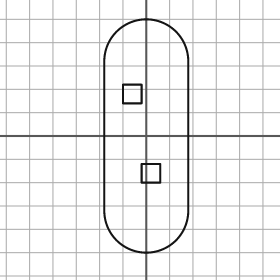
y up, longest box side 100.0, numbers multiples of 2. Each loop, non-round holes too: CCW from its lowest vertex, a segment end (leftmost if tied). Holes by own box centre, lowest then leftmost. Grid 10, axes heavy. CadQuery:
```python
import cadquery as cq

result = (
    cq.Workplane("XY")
    .moveTo(-18.0, -32.0)
    .threePointArc((0.0, -50.0), (18.0, -32.0))
    .lineTo(18.0, 32.0)
    .threePointArc((0.0, 50.0), (-18.0, 32.0))
    .close()
    .moveTo(-2.0, -20.0)
    .lineTo(6.0, -20.0)
    .lineTo(6.0, -12.0)
    .lineTo(-2.0, -12.0)
    .close()
    .moveTo(-10.0, 14.0)
    .lineTo(-2.0, 14.0)
    .lineTo(-2.0, 22.0)
    .lineTo(-10.0, 22.0)
    .close()
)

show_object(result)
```